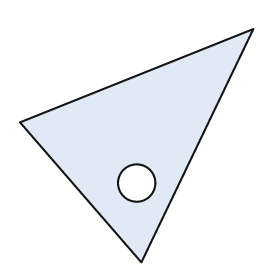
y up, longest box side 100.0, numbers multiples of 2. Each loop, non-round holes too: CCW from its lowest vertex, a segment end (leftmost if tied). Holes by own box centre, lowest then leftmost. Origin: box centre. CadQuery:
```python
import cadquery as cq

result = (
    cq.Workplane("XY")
    .moveTo(2.0, -50.0)
    .lineTo(50.0, 50.0)
    .lineTo(-50.0, 10.0)
    .close()
    .moveTo(0.0, -16.0)
    .circle(8.0)
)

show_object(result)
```